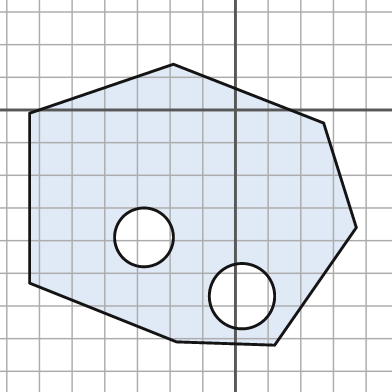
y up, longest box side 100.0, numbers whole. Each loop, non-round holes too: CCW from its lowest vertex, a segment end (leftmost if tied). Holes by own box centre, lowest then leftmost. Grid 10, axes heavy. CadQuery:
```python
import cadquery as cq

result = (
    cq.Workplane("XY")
    .moveTo(12.0, -72.0)
    .lineTo(37.0, -36.0)
    .lineTo(27.0, -4.0)
    .lineTo(-19.0, 14.0)
    .lineTo(-63.0, -1.0)
    .lineTo(-63.0, -53.0)
    .lineTo(-18.0, -71.0)
    .close()
    .moveTo(2.0, -57.0)
    .circle(10.0)
    .moveTo(-28.0, -39.0)
    .circle(9.0)
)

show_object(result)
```